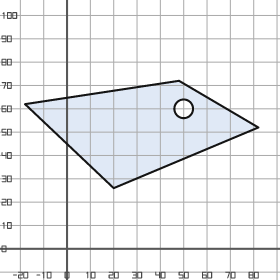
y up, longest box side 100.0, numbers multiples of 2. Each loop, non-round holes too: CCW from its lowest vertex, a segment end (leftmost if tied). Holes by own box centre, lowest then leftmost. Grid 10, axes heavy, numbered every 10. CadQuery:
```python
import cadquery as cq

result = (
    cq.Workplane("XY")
    .moveTo(20.0, 26.0)
    .lineTo(82.0, 52.0)
    .lineTo(48.0, 72.0)
    .lineTo(-18.0, 62.0)
    .close()
    .moveTo(50.0, 60.0)
    .circle(4.0)
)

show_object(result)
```